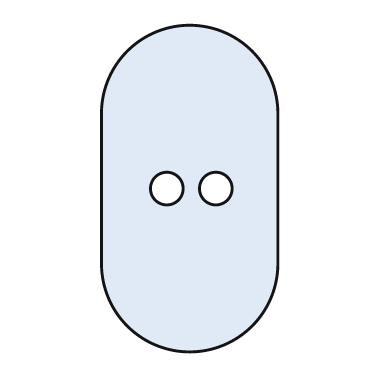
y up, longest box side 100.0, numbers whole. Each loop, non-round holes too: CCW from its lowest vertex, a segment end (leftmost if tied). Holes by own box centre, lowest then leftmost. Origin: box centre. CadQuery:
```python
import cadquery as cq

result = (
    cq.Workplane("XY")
    .moveTo(-27.0, -23.0)
    .threePointArc((0.0, -50.0), (27.0, -23.0))
    .lineTo(27.0, 23.0)
    .threePointArc((0.0, 50.0), (-27.0, 23.0))
    .close()
    .moveTo(-7.0, 0.0)
    .circle(5.0)
    .moveTo(8.0, 0.0)
    .circle(5.0)
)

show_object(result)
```